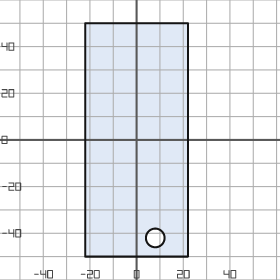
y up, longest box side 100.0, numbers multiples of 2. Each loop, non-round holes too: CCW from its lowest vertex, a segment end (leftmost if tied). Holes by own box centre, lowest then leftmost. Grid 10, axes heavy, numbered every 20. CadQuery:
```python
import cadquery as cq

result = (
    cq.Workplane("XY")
    .moveTo(-22.0, -50.0)
    .lineTo(22.0, -50.0)
    .lineTo(22.0, 50.0)
    .lineTo(-22.0, 50.0)
    .close()
    .moveTo(8.0, -42.0)
    .circle(4.0)
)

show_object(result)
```